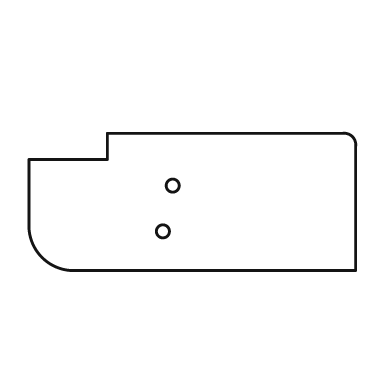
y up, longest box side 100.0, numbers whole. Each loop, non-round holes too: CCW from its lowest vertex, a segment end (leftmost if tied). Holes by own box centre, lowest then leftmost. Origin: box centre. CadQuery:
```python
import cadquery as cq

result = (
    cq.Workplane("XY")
    .moveTo(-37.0, -21.0)
    .lineTo(50.0, -21.0)
    .lineTo(50.0, 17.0)
    .threePointArc((49.0, 20.0), (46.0, 21.0))
    .lineTo(-26.0, 21.0)
    .lineTo(-26.0, 13.0)
    .lineTo(-50.0, 13.0)
    .lineTo(-50.0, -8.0)
    .threePointArc((-46.0, -17.0), (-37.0, -21.0))
    .close()
    .moveTo(-9.0, -9.0)
    .circle(2.0)
    .moveTo(-6.0, 5.0)
    .circle(2.0)
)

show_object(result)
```